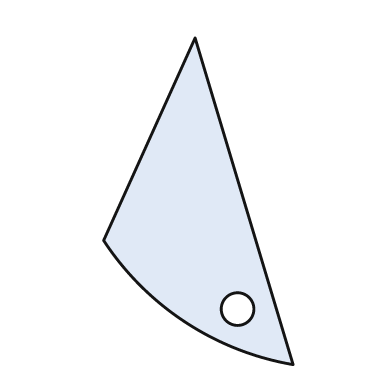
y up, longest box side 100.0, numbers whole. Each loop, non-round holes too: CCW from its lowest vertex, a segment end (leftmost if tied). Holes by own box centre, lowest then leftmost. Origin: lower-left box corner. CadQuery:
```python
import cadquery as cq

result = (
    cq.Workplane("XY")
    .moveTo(58.0, 0.0)
    .lineTo(28.0, 100.0)
    .lineTo(0.0, 38.0)
    .threePointArc((25.0, 13.0), (58.0, 0.0))
    .close()
    .moveTo(41.0, 17.0)
    .circle(5.0)
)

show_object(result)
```